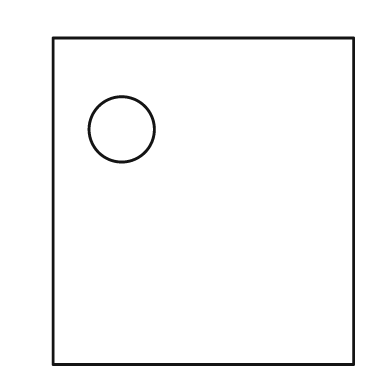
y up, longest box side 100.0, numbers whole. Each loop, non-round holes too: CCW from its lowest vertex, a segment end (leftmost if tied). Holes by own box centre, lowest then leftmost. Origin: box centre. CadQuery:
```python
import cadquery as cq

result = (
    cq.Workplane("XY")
    .moveTo(-46.0, -50.0)
    .lineTo(46.0, -50.0)
    .lineTo(46.0, 50.0)
    .lineTo(-46.0, 50.0)
    .close()
    .moveTo(-25.0, 22.0)
    .circle(10.0)
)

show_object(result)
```